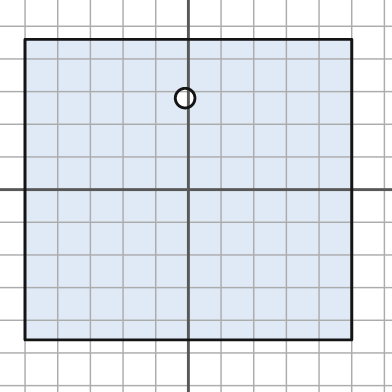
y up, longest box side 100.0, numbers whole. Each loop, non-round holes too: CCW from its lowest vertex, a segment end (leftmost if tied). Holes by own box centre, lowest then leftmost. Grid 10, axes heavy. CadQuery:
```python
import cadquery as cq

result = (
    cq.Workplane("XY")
    .moveTo(-50.0, -46.0)
    .lineTo(50.0, -46.0)
    .lineTo(50.0, 46.0)
    .lineTo(-50.0, 46.0)
    .close()
    .moveTo(-1.0, 28.0)
    .circle(3.0)
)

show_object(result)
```